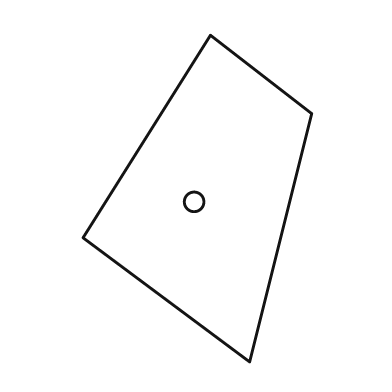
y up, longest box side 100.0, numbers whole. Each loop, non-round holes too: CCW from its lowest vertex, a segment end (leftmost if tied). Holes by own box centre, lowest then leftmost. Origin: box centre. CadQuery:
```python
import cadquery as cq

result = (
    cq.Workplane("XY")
    .moveTo(16.0, -50.0)
    .lineTo(35.0, 26.0)
    .lineTo(4.0, 50.0)
    .lineTo(-35.0, -12.0)
    .close()
    .moveTo(-1.0, -1.0)
    .circle(3.0)
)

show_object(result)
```